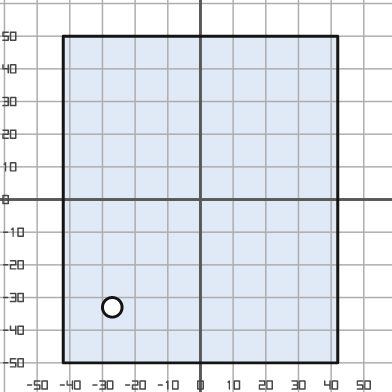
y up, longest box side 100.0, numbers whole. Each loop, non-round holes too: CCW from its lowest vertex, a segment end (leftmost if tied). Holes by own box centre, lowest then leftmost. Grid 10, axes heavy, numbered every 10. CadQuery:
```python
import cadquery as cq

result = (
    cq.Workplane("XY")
    .moveTo(-42.0, -50.0)
    .lineTo(42.0, -50.0)
    .lineTo(42.0, 50.0)
    .lineTo(-42.0, 50.0)
    .close()
    .moveTo(-27.0, -33.0)
    .circle(3.0)
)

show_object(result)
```